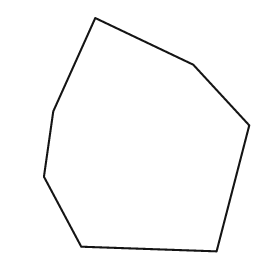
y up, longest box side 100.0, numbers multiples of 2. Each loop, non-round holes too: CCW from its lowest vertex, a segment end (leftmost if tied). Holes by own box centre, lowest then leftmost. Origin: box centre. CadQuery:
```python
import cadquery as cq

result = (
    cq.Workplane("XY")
    .moveTo(30.0, -50.0)
    .lineTo(44.0, 4.0)
    .lineTo(20.0, 30.0)
    .lineTo(-22.0, 50.0)
    .lineTo(-40.0, 10.0)
    .lineTo(-44.0, -18.0)
    .lineTo(-28.0, -48.0)
    .close()
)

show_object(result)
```